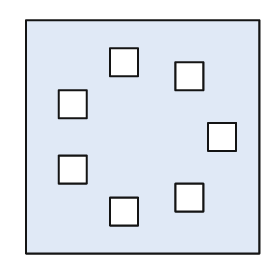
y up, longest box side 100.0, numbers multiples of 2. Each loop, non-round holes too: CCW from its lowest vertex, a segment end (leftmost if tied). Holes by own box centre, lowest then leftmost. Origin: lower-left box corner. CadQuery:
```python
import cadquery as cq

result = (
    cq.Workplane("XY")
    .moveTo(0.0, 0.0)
    .lineTo(100.0, 0.0)
    .lineTo(100.0, 100.0)
    .lineTo(0.0, 100.0)
    .close()
    .moveTo(36.0, 12.0)
    .lineTo(48.0, 12.0)
    .lineTo(48.0, 24.0)
    .lineTo(36.0, 24.0)
    .close()
    .moveTo(64.0, 18.0)
    .lineTo(76.0, 18.0)
    .lineTo(76.0, 30.0)
    .lineTo(64.0, 30.0)
    .close()
    .moveTo(14.0, 30.0)
    .lineTo(26.0, 30.0)
    .lineTo(26.0, 42.0)
    .lineTo(14.0, 42.0)
    .close()
    .moveTo(78.0, 44.0)
    .lineTo(90.0, 44.0)
    .lineTo(90.0, 56.0)
    .lineTo(78.0, 56.0)
    .close()
    .moveTo(14.0, 58.0)
    .lineTo(26.0, 58.0)
    .lineTo(26.0, 70.0)
    .lineTo(14.0, 70.0)
    .close()
    .moveTo(64.0, 70.0)
    .lineTo(76.0, 70.0)
    .lineTo(76.0, 82.0)
    .lineTo(64.0, 82.0)
    .close()
    .moveTo(36.0, 76.0)
    .lineTo(48.0, 76.0)
    .lineTo(48.0, 88.0)
    .lineTo(36.0, 88.0)
    .close()
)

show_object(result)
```